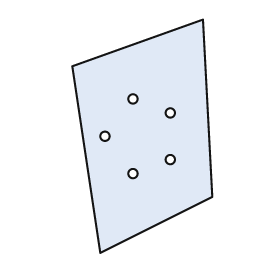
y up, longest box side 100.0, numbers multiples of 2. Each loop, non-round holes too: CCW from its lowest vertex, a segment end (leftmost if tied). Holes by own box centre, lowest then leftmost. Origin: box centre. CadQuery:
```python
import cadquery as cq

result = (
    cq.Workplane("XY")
    .moveTo(-18.0, -50.0)
    .lineTo(30.0, -26.0)
    .lineTo(26.0, 50.0)
    .lineTo(-30.0, 30.0)
    .close()
    .moveTo(-4.0, -16.0)
    .circle(2.0)
    .moveTo(12.0, -10.0)
    .circle(2.0)
    .moveTo(-16.0, 0.0)
    .circle(2.0)
    .moveTo(12.0, 10.0)
    .circle(2.0)
    .moveTo(-4.0, 16.0)
    .circle(2.0)
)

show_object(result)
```